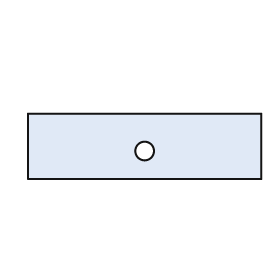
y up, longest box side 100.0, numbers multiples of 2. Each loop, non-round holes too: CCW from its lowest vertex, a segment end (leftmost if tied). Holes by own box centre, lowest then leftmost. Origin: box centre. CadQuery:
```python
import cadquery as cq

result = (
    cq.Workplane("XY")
    .moveTo(-50.0, -14.0)
    .lineTo(50.0, -14.0)
    .lineTo(50.0, 14.0)
    .lineTo(-50.0, 14.0)
    .close()
    .moveTo(0.0, -2.0)
    .circle(4.0)
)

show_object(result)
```